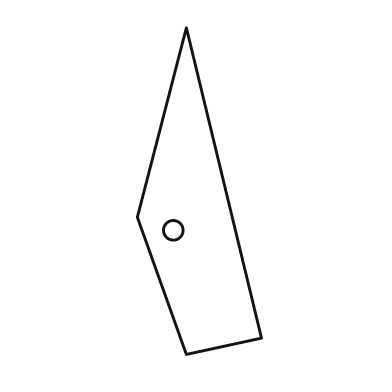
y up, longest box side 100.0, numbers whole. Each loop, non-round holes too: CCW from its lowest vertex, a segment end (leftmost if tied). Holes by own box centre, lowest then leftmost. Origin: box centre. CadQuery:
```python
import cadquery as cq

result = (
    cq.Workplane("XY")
    .moveTo(-4.0, -50.0)
    .lineTo(19.0, -45.0)
    .lineTo(-4.0, 50.0)
    .lineTo(-19.0, -8.0)
    .close()
    .moveTo(-8.0, -12.0)
    .circle(3.0)
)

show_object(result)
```